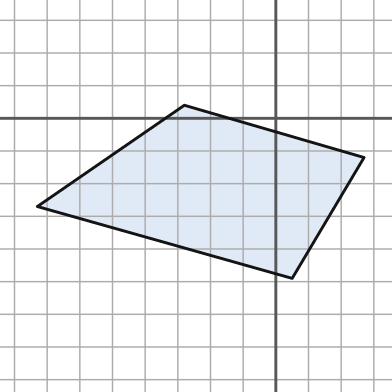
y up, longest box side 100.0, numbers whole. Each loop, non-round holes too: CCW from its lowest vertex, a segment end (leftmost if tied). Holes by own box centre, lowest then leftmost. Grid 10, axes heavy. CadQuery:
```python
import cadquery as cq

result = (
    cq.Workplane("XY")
    .moveTo(5.0, -49.0)
    .lineTo(27.0, -12.0)
    .lineTo(-28.0, 4.0)
    .lineTo(-73.0, -27.0)
    .close()
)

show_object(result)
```